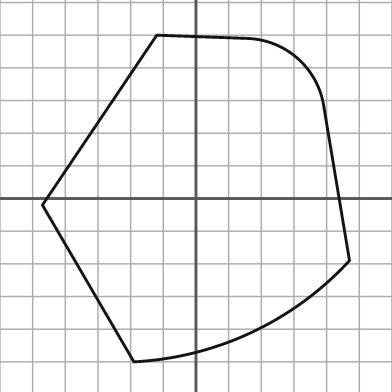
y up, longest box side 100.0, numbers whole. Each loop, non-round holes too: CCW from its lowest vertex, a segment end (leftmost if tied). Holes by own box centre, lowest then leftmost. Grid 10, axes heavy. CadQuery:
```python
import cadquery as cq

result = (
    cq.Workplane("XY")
    .moveTo(-19.0, -50.0)
    .threePointArc((17.0, -41.0), (47.0, -19.0))
    .lineTo(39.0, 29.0)
    .threePointArc((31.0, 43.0), (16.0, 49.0))
    .lineTo(-12.0, 50.0)
    .lineTo(-47.0, -2.0)
    .close()
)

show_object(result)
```